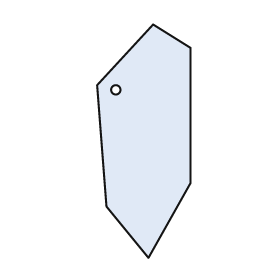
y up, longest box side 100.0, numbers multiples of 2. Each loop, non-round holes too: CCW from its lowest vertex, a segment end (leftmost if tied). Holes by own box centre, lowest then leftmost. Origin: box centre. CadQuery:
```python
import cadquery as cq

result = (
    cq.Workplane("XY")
    .moveTo(2.0, -50.0)
    .lineTo(20.0, -18.0)
    .lineTo(20.0, 40.0)
    .lineTo(4.0, 50.0)
    .lineTo(-20.0, 24.0)
    .lineTo(-16.0, -28.0)
    .close()
    .moveTo(-12.0, 22.0)
    .circle(2.0)
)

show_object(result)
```